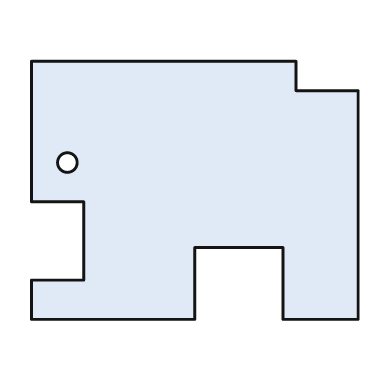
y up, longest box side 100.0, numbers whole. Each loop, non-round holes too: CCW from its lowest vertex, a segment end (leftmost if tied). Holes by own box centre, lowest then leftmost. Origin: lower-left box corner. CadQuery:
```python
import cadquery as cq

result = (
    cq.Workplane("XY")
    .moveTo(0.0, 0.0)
    .lineTo(50.0, 0.0)
    .lineTo(50.0, 22.0)
    .lineTo(77.0, 22.0)
    .lineTo(77.0, 0.0)
    .lineTo(100.0, 0.0)
    .lineTo(100.0, 70.0)
    .lineTo(81.0, 70.0)
    .lineTo(81.0, 79.0)
    .lineTo(0.0, 79.0)
    .lineTo(0.0, 36.0)
    .lineTo(16.0, 36.0)
    .lineTo(16.0, 12.0)
    .lineTo(0.0, 12.0)
    .close()
    .moveTo(11.0, 48.0)
    .circle(3.0)
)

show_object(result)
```